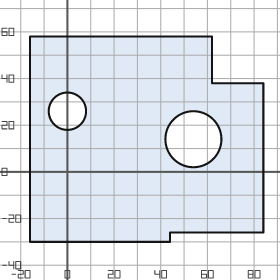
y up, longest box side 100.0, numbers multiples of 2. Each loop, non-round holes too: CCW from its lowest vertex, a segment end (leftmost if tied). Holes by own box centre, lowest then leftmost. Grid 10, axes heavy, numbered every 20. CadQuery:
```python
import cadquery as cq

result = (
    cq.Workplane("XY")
    .moveTo(-16.0, -30.0)
    .lineTo(44.0, -30.0)
    .lineTo(44.0, -26.0)
    .lineTo(84.0, -26.0)
    .lineTo(84.0, 38.0)
    .lineTo(62.0, 38.0)
    .lineTo(62.0, 58.0)
    .lineTo(-16.0, 58.0)
    .close()
    .moveTo(54.0, 14.0)
    .circle(12.0)
    .moveTo(0.0, 26.0)
    .circle(8.0)
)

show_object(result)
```